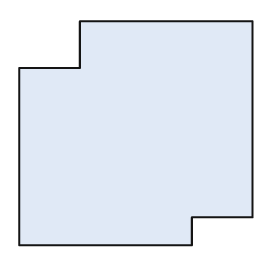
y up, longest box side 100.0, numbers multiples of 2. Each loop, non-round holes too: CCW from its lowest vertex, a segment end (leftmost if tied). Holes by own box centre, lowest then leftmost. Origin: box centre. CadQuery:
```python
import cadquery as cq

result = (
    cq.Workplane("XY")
    .moveTo(-50.0, -48.0)
    .lineTo(24.0, -48.0)
    .lineTo(24.0, -36.0)
    .lineTo(50.0, -36.0)
    .lineTo(50.0, 48.0)
    .lineTo(-24.0, 48.0)
    .lineTo(-24.0, 28.0)
    .lineTo(-50.0, 28.0)
    .close()
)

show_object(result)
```